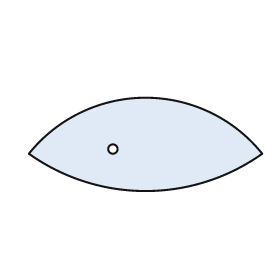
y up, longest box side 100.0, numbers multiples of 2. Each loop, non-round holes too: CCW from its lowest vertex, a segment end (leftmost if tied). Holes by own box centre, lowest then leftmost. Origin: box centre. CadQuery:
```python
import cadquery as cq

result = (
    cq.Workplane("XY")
    .moveTo(-50.0, -4.0)
    .threePointArc((0.0, -20.0), (50.0, -4.0))
    .threePointArc((0.0, 20.0), (-50.0, -4.0))
    .close()
    .moveTo(-14.0, -2.0)
    .circle(2.0)
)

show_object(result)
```